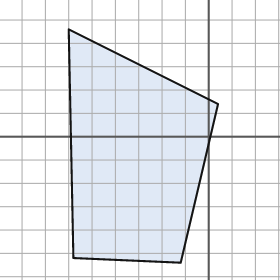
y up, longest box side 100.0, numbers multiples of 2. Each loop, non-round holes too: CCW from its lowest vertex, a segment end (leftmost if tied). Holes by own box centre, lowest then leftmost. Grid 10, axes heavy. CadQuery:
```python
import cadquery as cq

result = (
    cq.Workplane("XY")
    .moveTo(-12.0, -54.0)
    .lineTo(4.0, 14.0)
    .lineTo(-60.0, 46.0)
    .lineTo(-58.0, -52.0)
    .close()
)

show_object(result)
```